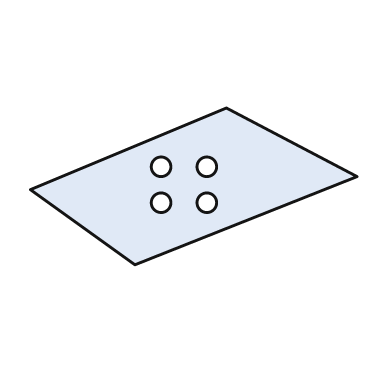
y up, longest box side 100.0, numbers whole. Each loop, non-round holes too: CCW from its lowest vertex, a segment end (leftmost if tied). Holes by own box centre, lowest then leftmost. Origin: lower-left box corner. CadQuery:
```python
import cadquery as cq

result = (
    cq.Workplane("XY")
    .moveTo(32.0, 0.0)
    .lineTo(100.0, 27.0)
    .lineTo(60.0, 48.0)
    .lineTo(0.0, 23.0)
    .close()
    .moveTo(40.0, 19.0)
    .circle(3.0)
    .moveTo(54.0, 19.0)
    .circle(3.0)
    .moveTo(40.0, 30.0)
    .circle(3.0)
    .moveTo(54.0, 30.0)
    .circle(3.0)
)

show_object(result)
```